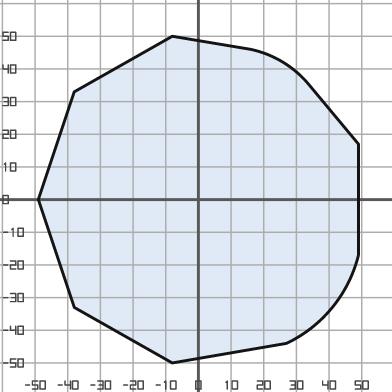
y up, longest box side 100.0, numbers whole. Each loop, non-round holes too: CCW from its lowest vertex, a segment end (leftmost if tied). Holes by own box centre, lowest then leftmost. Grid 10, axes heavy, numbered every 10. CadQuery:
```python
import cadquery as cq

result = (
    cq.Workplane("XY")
    .moveTo(-8.0, -50.0)
    .lineTo(27.0, -44.0)
    .threePointArc((41.0, -33.0), (49.0, -17.0))
    .lineTo(49.0, 17.0)
    .lineTo(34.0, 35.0)
    .threePointArc((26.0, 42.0), (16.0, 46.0))
    .lineTo(-8.0, 50.0)
    .lineTo(-38.0, 33.0)
    .lineTo(-49.0, 0.0)
    .lineTo(-38.0, -33.0)
    .close()
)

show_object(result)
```